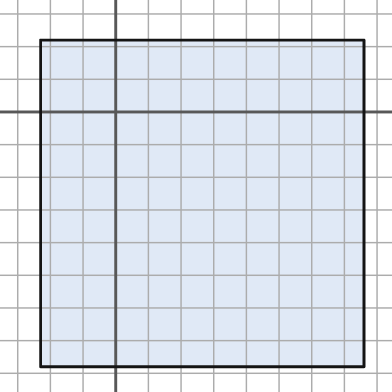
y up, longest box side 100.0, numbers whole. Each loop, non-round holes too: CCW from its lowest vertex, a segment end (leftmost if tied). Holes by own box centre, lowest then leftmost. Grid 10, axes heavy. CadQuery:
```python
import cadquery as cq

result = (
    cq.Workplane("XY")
    .moveTo(-23.0, -78.0)
    .lineTo(76.0, -78.0)
    .lineTo(76.0, 22.0)
    .lineTo(-23.0, 22.0)
    .close()
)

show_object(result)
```